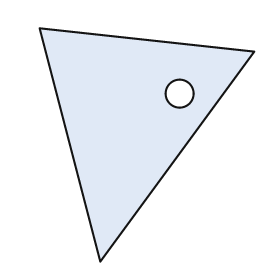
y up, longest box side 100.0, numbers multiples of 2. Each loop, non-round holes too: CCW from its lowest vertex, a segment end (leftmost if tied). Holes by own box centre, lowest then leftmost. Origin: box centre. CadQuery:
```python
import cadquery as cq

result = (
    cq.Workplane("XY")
    .moveTo(-20.0, -50.0)
    .lineTo(46.0, 40.0)
    .lineTo(-46.0, 50.0)
    .close()
    .moveTo(14.0, 22.0)
    .circle(6.0)
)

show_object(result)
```